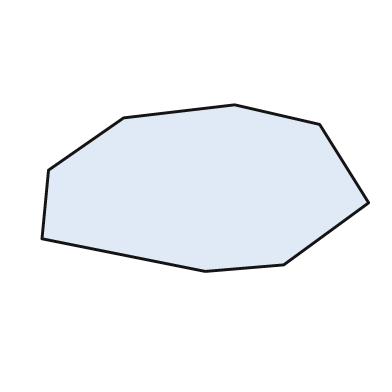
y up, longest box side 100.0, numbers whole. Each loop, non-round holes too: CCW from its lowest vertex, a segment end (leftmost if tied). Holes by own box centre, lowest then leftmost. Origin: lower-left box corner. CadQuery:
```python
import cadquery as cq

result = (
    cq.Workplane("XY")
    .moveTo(50.0, 0.0)
    .lineTo(74.0, 2.0)
    .lineTo(100.0, 21.0)
    .lineTo(85.0, 45.0)
    .lineTo(59.0, 51.0)
    .lineTo(25.0, 47.0)
    .lineTo(2.0, 31.0)
    .lineTo(0.0, 10.0)
    .close()
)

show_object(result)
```